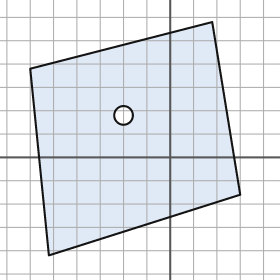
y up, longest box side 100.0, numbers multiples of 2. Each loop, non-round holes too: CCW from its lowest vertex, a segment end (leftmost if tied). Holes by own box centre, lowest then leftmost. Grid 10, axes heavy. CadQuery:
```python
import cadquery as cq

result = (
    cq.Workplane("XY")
    .moveTo(-52.0, -42.0)
    .lineTo(30.0, -16.0)
    .lineTo(18.0, 58.0)
    .lineTo(-60.0, 38.0)
    .close()
    .moveTo(-20.0, 18.0)
    .circle(4.0)
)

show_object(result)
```